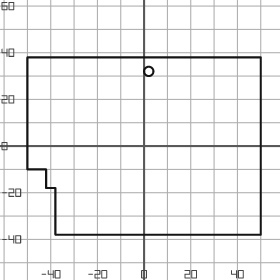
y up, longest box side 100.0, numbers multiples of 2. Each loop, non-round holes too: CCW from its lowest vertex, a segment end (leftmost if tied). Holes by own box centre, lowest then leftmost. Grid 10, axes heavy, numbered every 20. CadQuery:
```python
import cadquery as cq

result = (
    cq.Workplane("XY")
    .moveTo(-38.0, -38.0)
    .lineTo(50.0, -38.0)
    .lineTo(50.0, 38.0)
    .lineTo(-50.0, 38.0)
    .lineTo(-50.0, -10.0)
    .lineTo(-42.0, -10.0)
    .lineTo(-42.0, -18.0)
    .lineTo(-38.0, -18.0)
    .close()
    .moveTo(2.0, 32.0)
    .circle(2.0)
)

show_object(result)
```